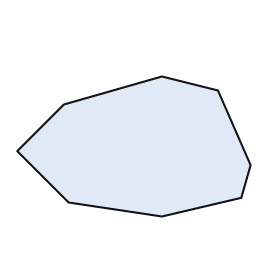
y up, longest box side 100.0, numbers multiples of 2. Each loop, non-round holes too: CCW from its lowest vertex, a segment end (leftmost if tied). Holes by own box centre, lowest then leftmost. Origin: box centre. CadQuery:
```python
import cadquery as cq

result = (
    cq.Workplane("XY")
    .moveTo(12.0, -30.0)
    .lineTo(46.0, -22.0)
    .lineTo(50.0, -8.0)
    .lineTo(36.0, 24.0)
    .lineTo(12.0, 30.0)
    .lineTo(-30.0, 18.0)
    .lineTo(-50.0, -2.0)
    .lineTo(-28.0, -24.0)
    .close()
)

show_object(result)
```